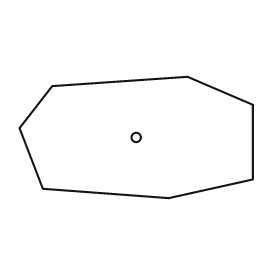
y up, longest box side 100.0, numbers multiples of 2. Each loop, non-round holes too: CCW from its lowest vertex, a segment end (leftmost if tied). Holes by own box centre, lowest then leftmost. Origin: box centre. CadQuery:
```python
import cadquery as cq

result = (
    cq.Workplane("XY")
    .moveTo(14.0, -26.0)
    .lineTo(50.0, -18.0)
    .lineTo(50.0, 14.0)
    .lineTo(22.0, 26.0)
    .lineTo(-36.0, 22.0)
    .lineTo(-50.0, 4.0)
    .lineTo(-40.0, -22.0)
    .close()
    .moveTo(0.0, 0.0)
    .circle(2.0)
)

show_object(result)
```